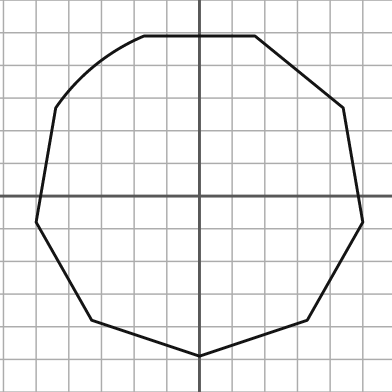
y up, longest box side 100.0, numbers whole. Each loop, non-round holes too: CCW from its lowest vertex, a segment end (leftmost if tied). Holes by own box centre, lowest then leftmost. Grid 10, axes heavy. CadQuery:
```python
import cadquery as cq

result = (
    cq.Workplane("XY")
    .moveTo(0.0, -49.0)
    .lineTo(33.0, -38.0)
    .lineTo(50.0, -8.0)
    .lineTo(44.0, 27.0)
    .lineTo(17.0, 49.0)
    .lineTo(-17.0, 49.0)
    .threePointArc((-32.0, 40.0), (-44.0, 27.0))
    .lineTo(-50.0, -8.0)
    .lineTo(-33.0, -38.0)
    .close()
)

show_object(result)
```